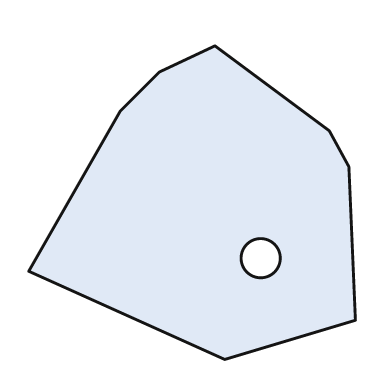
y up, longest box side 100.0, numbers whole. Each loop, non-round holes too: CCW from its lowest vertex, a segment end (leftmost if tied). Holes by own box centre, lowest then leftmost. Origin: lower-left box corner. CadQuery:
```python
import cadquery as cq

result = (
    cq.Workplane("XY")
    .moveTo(60.0, 0.0)
    .lineTo(100.0, 12.0)
    .lineTo(98.0, 59.0)
    .lineTo(92.0, 70.0)
    .lineTo(57.0, 96.0)
    .lineTo(40.0, 88.0)
    .lineTo(28.0, 76.0)
    .lineTo(0.0, 27.0)
    .close()
    .moveTo(71.0, 31.0)
    .circle(6.0)
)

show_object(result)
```